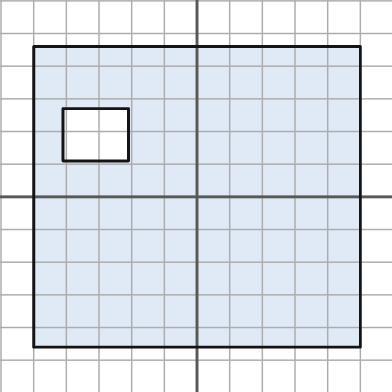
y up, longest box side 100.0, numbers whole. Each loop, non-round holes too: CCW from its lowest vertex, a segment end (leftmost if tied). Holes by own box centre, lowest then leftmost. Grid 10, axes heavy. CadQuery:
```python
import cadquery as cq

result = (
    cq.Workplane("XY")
    .moveTo(-50.0, -46.0)
    .lineTo(50.0, -46.0)
    .lineTo(50.0, 46.0)
    .lineTo(-50.0, 46.0)
    .close()
    .moveTo(-41.0, 11.0)
    .lineTo(-21.0, 11.0)
    .lineTo(-21.0, 27.0)
    .lineTo(-41.0, 27.0)
    .close()
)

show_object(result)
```